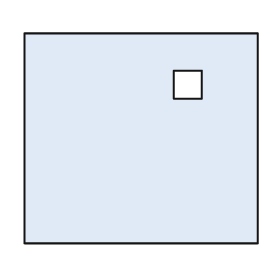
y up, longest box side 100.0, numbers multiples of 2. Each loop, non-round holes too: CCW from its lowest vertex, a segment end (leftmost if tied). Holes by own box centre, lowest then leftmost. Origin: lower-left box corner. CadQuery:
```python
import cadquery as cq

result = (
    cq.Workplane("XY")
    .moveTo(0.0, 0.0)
    .lineTo(100.0, 0.0)
    .lineTo(100.0, 90.0)
    .lineTo(0.0, 90.0)
    .close()
    .moveTo(64.0, 62.0)
    .lineTo(76.0, 62.0)
    .lineTo(76.0, 74.0)
    .lineTo(64.0, 74.0)
    .close()
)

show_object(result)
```